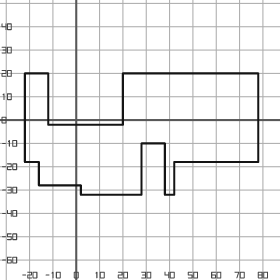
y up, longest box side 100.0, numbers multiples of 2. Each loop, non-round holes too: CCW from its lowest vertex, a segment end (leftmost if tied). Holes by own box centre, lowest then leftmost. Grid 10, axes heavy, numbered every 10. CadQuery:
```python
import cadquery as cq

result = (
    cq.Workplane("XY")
    .moveTo(2.0, -32.0)
    .lineTo(28.0, -32.0)
    .lineTo(28.0, -10.0)
    .lineTo(38.0, -10.0)
    .lineTo(38.0, -32.0)
    .lineTo(42.0, -32.0)
    .lineTo(42.0, -18.0)
    .lineTo(78.0, -18.0)
    .lineTo(78.0, 20.0)
    .lineTo(20.0, 20.0)
    .lineTo(20.0, -2.0)
    .lineTo(-12.0, -2.0)
    .lineTo(-12.0, 20.0)
    .lineTo(-22.0, 20.0)
    .lineTo(-22.0, -18.0)
    .lineTo(-16.0, -18.0)
    .lineTo(-16.0, -28.0)
    .lineTo(2.0, -28.0)
    .close()
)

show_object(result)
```